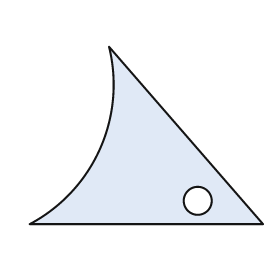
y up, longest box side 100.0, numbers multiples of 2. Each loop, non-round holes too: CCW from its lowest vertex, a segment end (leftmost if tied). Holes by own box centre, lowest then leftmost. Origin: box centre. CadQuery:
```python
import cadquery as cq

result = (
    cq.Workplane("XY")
    .moveTo(-50.0, -38.0)
    .lineTo(50.0, -38.0)
    .lineTo(-16.0, 38.0)
    .threePointArc((-20.0, -6.0), (-50.0, -38.0))
    .close()
    .moveTo(22.0, -28.0)
    .circle(6.0)
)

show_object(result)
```